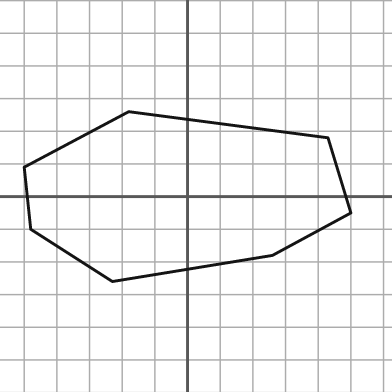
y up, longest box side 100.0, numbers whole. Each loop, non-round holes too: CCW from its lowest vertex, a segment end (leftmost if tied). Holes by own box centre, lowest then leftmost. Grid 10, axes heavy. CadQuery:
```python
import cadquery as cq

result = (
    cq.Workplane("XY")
    .moveTo(-23.0, -26.0)
    .lineTo(26.0, -18.0)
    .lineTo(50.0, -5.0)
    .lineTo(43.0, 18.0)
    .lineTo(-18.0, 26.0)
    .lineTo(-50.0, 9.0)
    .lineTo(-48.0, -10.0)
    .close()
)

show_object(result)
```